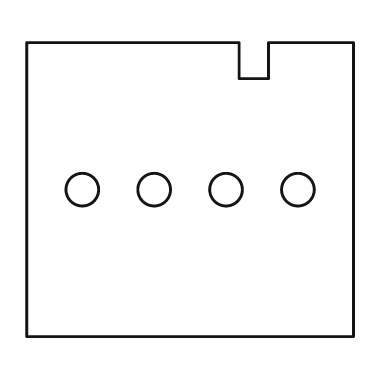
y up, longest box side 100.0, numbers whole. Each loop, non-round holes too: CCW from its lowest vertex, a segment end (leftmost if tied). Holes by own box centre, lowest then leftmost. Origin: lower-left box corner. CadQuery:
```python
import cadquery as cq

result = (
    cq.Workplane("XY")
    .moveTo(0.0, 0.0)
    .lineTo(100.0, 0.0)
    .lineTo(100.0, 90.0)
    .lineTo(74.0, 90.0)
    .lineTo(74.0, 79.0)
    .lineTo(65.0, 79.0)
    .lineTo(65.0, 90.0)
    .lineTo(0.0, 90.0)
    .close()
    .moveTo(17.0, 45.0)
    .circle(5.0)
    .moveTo(39.0, 45.0)
    .circle(5.0)
    .moveTo(61.0, 45.0)
    .circle(5.0)
    .moveTo(83.0, 45.0)
    .circle(5.0)
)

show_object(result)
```